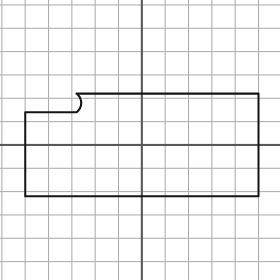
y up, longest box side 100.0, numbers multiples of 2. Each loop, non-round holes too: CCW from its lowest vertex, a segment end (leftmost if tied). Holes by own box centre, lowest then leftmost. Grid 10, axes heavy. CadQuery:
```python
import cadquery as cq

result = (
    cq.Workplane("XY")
    .moveTo(-50.0, -22.0)
    .lineTo(50.0, -22.0)
    .lineTo(50.0, 22.0)
    .lineTo(-28.0, 22.0)
    .threePointArc((-26.0, 18.0), (-28.0, 14.0))
    .lineTo(-50.0, 14.0)
    .close()
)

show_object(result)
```